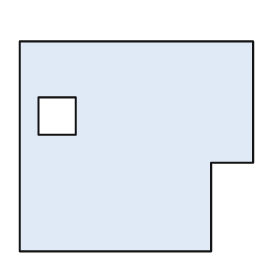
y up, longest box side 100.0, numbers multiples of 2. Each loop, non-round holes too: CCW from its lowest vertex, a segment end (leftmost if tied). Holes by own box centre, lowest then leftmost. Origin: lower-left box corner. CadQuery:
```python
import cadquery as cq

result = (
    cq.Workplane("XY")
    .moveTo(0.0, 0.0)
    .lineTo(82.0, 0.0)
    .lineTo(82.0, 38.0)
    .lineTo(100.0, 38.0)
    .lineTo(100.0, 90.0)
    .lineTo(0.0, 90.0)
    .close()
    .moveTo(8.0, 50.0)
    .lineTo(24.0, 50.0)
    .lineTo(24.0, 66.0)
    .lineTo(8.0, 66.0)
    .close()
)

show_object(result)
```